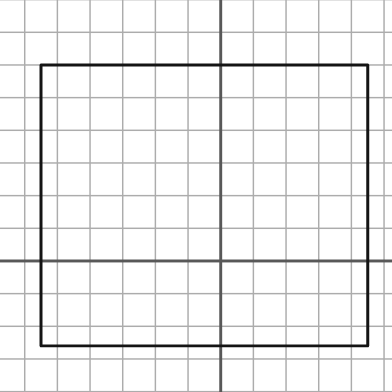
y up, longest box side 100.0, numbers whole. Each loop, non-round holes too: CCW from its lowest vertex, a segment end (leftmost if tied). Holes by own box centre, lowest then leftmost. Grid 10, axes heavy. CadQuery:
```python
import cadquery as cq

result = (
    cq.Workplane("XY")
    .moveTo(-55.0, -26.0)
    .lineTo(45.0, -26.0)
    .lineTo(45.0, 60.0)
    .lineTo(-55.0, 60.0)
    .close()
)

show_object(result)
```